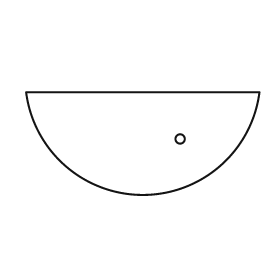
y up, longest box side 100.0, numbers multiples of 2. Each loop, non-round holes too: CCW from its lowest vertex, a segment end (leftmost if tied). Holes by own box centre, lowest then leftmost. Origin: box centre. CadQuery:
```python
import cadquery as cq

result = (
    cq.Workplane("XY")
    .moveTo(-50.0, 22.0)
    .threePointArc((0.0, -22.0), (50.0, 22.0))
    .close()
    .moveTo(16.0, 2.0)
    .circle(2.0)
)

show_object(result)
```